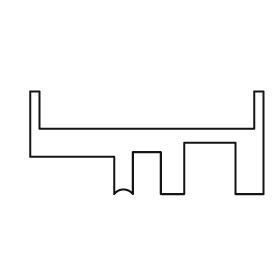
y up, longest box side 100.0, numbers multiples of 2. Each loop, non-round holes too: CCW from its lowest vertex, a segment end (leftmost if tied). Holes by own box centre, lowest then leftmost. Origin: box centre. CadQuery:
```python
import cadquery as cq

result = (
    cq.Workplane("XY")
    .moveTo(-14.0, -22.0)
    .threePointArc((-10.0, -20.0), (-6.0, -22.0))
    .lineTo(-6.0, -4.0)
    .lineTo(6.0, -4.0)
    .lineTo(6.0, -22.0)
    .lineTo(16.0, -22.0)
    .lineTo(16.0, 0.0)
    .lineTo(38.0, 0.0)
    .lineTo(38.0, -22.0)
    .lineTo(50.0, -22.0)
    .lineTo(50.0, 22.0)
    .lineTo(46.0, 22.0)
    .lineTo(46.0, 6.0)
    .lineTo(-46.0, 6.0)
    .lineTo(-46.0, 22.0)
    .lineTo(-50.0, 22.0)
    .lineTo(-50.0, -6.0)
    .lineTo(-14.0, -6.0)
    .close()
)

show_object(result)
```